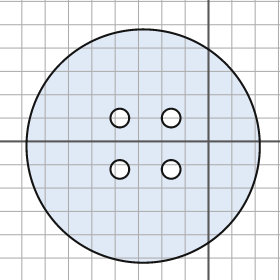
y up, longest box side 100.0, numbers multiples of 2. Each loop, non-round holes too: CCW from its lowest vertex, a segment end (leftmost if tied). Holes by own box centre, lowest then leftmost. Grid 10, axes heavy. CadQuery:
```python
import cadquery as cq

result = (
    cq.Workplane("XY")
    .moveTo(-28.0, -2.0)
    .circle(50.0)
    .moveTo(-38.0, -12.0)
    .circle(4.0)
    .moveTo(-16.0, -12.0)
    .circle(4.0)
    .moveTo(-38.0, 10.0)
    .circle(4.0)
    .moveTo(-16.0, 10.0)
    .circle(4.0)
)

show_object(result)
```